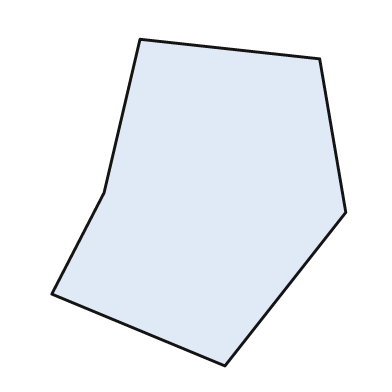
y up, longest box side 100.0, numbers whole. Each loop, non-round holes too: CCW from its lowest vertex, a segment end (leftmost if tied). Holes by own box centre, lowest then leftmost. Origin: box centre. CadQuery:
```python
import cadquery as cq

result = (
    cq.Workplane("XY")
    .moveTo(8.0, -50.0)
    .lineTo(45.0, -3.0)
    .lineTo(37.0, 44.0)
    .lineTo(-18.0, 50.0)
    .lineTo(-29.0, 3.0)
    .lineTo(-45.0, -28.0)
    .close()
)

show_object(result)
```